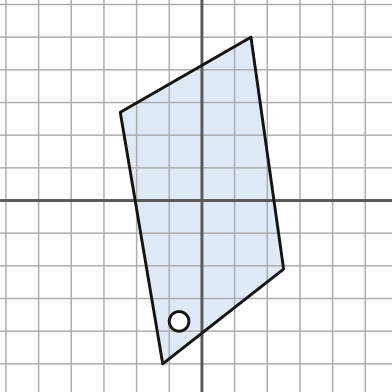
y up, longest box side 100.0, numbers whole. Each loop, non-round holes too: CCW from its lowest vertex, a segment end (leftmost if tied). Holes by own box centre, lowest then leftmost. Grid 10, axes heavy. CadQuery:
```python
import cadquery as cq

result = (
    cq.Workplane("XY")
    .moveTo(-12.0, -50.0)
    .lineTo(25.0, -21.0)
    .lineTo(15.0, 50.0)
    .lineTo(-25.0, 27.0)
    .close()
    .moveTo(-7.0, -37.0)
    .circle(3.0)
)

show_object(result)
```